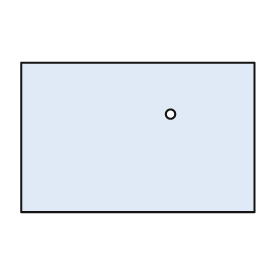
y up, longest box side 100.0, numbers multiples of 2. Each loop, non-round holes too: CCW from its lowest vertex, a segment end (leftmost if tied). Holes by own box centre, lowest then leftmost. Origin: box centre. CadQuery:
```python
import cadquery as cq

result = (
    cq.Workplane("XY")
    .moveTo(-50.0, -32.0)
    .lineTo(50.0, -32.0)
    .lineTo(50.0, 32.0)
    .lineTo(-50.0, 32.0)
    .close()
    .moveTo(14.0, 10.0)
    .circle(2.0)
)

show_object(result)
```